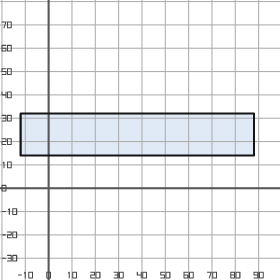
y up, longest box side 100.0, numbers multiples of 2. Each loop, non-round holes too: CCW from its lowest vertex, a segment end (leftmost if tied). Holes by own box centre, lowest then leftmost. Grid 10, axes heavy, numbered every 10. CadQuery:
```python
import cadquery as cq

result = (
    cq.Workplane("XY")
    .moveTo(-12.0, 14.0)
    .lineTo(88.0, 14.0)
    .lineTo(88.0, 32.0)
    .lineTo(-12.0, 32.0)
    .close()
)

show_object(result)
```